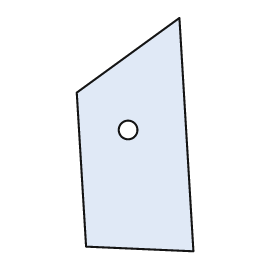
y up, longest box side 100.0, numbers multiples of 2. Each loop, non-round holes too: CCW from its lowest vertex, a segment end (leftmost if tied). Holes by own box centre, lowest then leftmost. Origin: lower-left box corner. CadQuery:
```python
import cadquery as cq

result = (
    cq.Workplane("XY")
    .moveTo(50.0, 0.0)
    .lineTo(44.0, 100.0)
    .lineTo(0.0, 68.0)
    .lineTo(4.0, 2.0)
    .close()
    .moveTo(22.0, 52.0)
    .circle(4.0)
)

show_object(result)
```